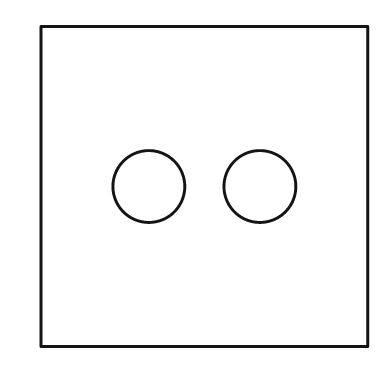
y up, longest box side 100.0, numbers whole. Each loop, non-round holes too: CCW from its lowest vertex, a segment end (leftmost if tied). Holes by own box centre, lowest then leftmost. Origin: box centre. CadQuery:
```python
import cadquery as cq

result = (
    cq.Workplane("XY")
    .moveTo(-50.0, -49.0)
    .lineTo(50.0, -49.0)
    .lineTo(50.0, 49.0)
    .lineTo(-50.0, 49.0)
    .close()
    .moveTo(-17.0, 0.0)
    .circle(11.0)
    .moveTo(17.0, 0.0)
    .circle(11.0)
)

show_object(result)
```